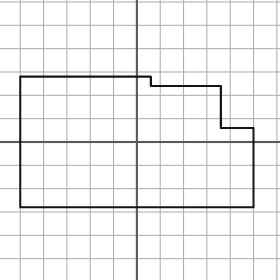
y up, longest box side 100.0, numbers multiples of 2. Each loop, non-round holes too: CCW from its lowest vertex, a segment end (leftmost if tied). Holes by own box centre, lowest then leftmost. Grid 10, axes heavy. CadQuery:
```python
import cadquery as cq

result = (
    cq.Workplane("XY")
    .moveTo(-50.0, -28.0)
    .lineTo(50.0, -28.0)
    .lineTo(50.0, 6.0)
    .lineTo(36.0, 6.0)
    .lineTo(36.0, 24.0)
    .lineTo(6.0, 24.0)
    .lineTo(6.0, 28.0)
    .lineTo(-50.0, 28.0)
    .close()
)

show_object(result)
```